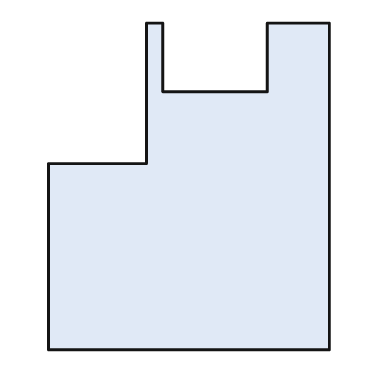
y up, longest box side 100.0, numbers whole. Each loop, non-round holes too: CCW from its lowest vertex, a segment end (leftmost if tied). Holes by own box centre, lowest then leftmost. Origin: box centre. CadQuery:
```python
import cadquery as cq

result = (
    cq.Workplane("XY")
    .moveTo(-43.0, -50.0)
    .lineTo(43.0, -50.0)
    .lineTo(43.0, 50.0)
    .lineTo(24.0, 50.0)
    .lineTo(24.0, 29.0)
    .lineTo(-8.0, 29.0)
    .lineTo(-8.0, 50.0)
    .lineTo(-13.0, 50.0)
    .lineTo(-13.0, 7.0)
    .lineTo(-43.0, 7.0)
    .close()
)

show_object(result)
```